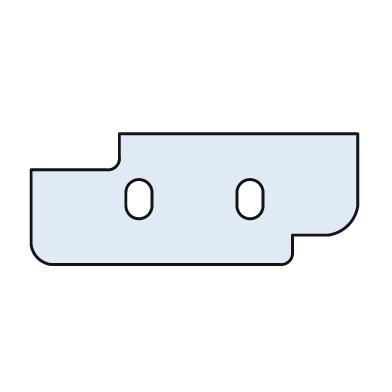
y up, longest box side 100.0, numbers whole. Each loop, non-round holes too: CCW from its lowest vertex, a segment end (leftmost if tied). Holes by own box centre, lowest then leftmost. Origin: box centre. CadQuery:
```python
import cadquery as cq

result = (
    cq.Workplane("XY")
    .moveTo(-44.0, -20.0)
    .lineTo(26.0, -20.0)
    .threePointArc((29.0, -19.0), (30.0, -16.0))
    .lineTo(30.0, -11.0)
    .lineTo(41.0, -11.0)
    .threePointArc((47.0, -8.0), (50.0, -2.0))
    .lineTo(50.0, 20.0)
    .lineTo(-23.0, 20.0)
    .lineTo(-23.0, 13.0)
    .threePointArc((-24.0, 10.0), (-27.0, 9.0))
    .lineTo(-50.0, 9.0)
    .lineTo(-50.0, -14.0)
    .threePointArc((-48.0, -18.0), (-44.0, -20.0))
    .close()
    .moveTo(-21.0, -2.0)
    .threePointArc((-17.0, -6.0), (-13.0, -2.0))
    .lineTo(-13.0, 2.0)
    .threePointArc((-17.0, 6.0), (-21.0, 2.0))
    .close()
    .moveTo(13.0, -2.0)
    .threePointArc((17.0, -6.0), (21.0, -2.0))
    .lineTo(21.0, 2.0)
    .threePointArc((17.0, 6.0), (13.0, 2.0))
    .close()
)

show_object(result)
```